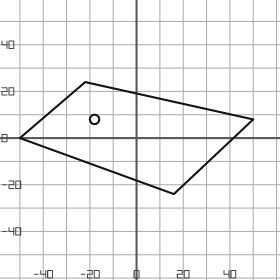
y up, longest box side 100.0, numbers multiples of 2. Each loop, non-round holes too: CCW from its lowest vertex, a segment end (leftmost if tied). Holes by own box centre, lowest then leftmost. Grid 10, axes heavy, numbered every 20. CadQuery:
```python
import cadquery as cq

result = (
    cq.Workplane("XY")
    .moveTo(16.0, -24.0)
    .lineTo(50.0, 8.0)
    .lineTo(-22.0, 24.0)
    .lineTo(-50.0, 0.0)
    .close()
    .moveTo(-18.0, 8.0)
    .circle(2.0)
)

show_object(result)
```